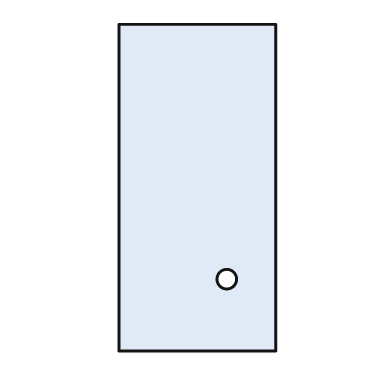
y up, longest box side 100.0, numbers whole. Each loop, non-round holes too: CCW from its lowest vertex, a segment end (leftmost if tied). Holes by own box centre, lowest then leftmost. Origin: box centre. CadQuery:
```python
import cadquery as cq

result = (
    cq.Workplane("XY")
    .moveTo(-24.0, -50.0)
    .lineTo(24.0, -50.0)
    .lineTo(24.0, 50.0)
    .lineTo(-24.0, 50.0)
    .close()
    .moveTo(9.0, -28.0)
    .circle(3.0)
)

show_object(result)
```